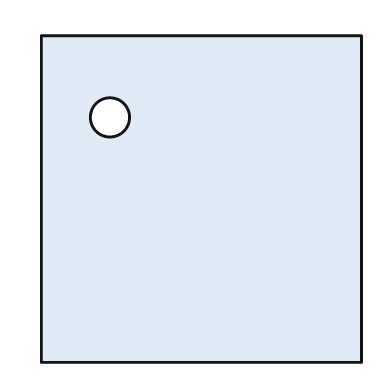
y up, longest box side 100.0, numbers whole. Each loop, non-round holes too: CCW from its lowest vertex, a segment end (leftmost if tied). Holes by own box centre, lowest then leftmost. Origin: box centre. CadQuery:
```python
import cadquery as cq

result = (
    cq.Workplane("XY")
    .moveTo(-49.0, -50.0)
    .lineTo(49.0, -50.0)
    .lineTo(49.0, 50.0)
    .lineTo(-49.0, 50.0)
    .close()
    .moveTo(-28.0, 25.0)
    .circle(6.0)
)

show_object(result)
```